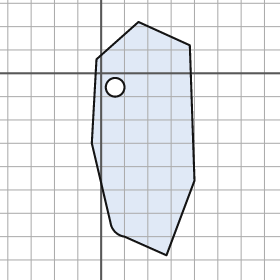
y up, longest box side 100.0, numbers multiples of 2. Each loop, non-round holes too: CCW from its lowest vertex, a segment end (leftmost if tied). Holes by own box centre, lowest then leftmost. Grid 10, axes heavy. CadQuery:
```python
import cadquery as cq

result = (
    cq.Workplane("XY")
    .moveTo(28.0, -78.0)
    .lineTo(40.0, -46.0)
    .lineTo(38.0, 12.0)
    .lineTo(16.0, 22.0)
    .lineTo(-2.0, 6.0)
    .lineTo(-4.0, -30.0)
    .lineTo(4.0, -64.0)
    .threePointArc((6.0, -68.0), (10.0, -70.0))
    .close()
    .moveTo(6.0, -6.0)
    .circle(4.0)
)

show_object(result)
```